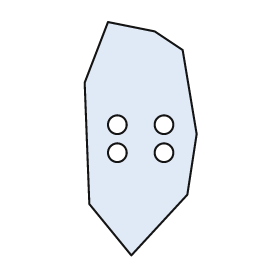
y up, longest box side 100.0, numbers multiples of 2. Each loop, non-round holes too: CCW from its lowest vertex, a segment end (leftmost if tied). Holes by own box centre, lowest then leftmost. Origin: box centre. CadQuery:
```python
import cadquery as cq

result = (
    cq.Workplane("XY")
    .moveTo(-4.0, -50.0)
    .lineTo(20.0, -24.0)
    .lineTo(24.0, 2.0)
    .lineTo(18.0, 38.0)
    .lineTo(6.0, 46.0)
    .lineTo(-14.0, 50.0)
    .lineTo(-24.0, 24.0)
    .lineTo(-22.0, -28.0)
    .close()
    .moveTo(-10.0, -6.0)
    .circle(4.0)
    .moveTo(10.0, -6.0)
    .circle(4.0)
    .moveTo(-10.0, 6.0)
    .circle(4.0)
    .moveTo(10.0, 6.0)
    .circle(4.0)
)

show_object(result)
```